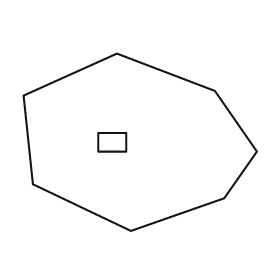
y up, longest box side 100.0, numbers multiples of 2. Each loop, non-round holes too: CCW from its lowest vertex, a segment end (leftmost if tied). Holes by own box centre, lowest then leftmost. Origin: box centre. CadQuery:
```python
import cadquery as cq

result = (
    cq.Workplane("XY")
    .moveTo(-4.0, -38.0)
    .lineTo(36.0, -24.0)
    .lineTo(50.0, -4.0)
    .lineTo(32.0, 22.0)
    .lineTo(-10.0, 38.0)
    .lineTo(-50.0, 20.0)
    .lineTo(-46.0, -18.0)
    .close()
    .moveTo(-18.0, -4.0)
    .lineTo(-6.0, -4.0)
    .lineTo(-6.0, 4.0)
    .lineTo(-18.0, 4.0)
    .close()
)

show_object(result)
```